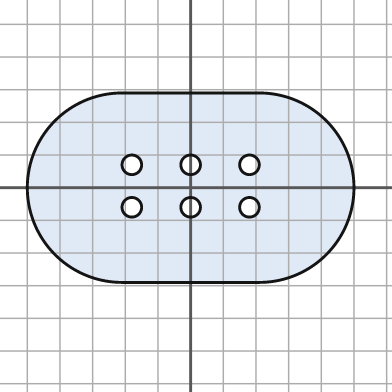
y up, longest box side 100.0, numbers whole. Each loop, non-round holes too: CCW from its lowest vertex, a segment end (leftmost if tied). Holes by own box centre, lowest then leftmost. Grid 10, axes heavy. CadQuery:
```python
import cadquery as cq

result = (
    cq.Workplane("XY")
    .moveTo(-21.0, -29.0)
    .lineTo(21.0, -29.0)
    .threePointArc((50.0, 0.0), (21.0, 29.0))
    .lineTo(-21.0, 29.0)
    .threePointArc((-50.0, 0.0), (-21.0, -29.0))
    .close()
    .moveTo(-18.0, -6.0)
    .circle(3.0)
    .moveTo(0.0, -6.0)
    .circle(3.0)
    .moveTo(18.0, -6.0)
    .circle(3.0)
    .moveTo(-18.0, 7.0)
    .circle(3.0)
    .moveTo(0.0, 7.0)
    .circle(3.0)
    .moveTo(18.0, 7.0)
    .circle(3.0)
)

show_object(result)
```